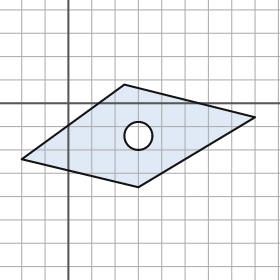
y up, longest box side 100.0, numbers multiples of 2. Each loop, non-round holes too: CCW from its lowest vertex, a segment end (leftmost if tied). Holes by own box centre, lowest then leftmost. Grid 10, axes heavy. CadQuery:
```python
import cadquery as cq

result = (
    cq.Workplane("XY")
    .moveTo(30.0, -36.0)
    .lineTo(80.0, -6.0)
    .lineTo(24.0, 8.0)
    .lineTo(-20.0, -24.0)
    .close()
    .moveTo(30.0, -14.0)
    .circle(6.0)
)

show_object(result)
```